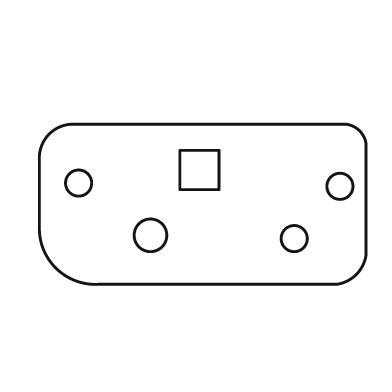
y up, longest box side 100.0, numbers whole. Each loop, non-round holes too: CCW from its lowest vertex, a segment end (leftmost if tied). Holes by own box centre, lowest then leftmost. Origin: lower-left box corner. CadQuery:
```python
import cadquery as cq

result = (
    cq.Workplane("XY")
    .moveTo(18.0, 0.0)
    .lineTo(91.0, 0.0)
    .threePointArc((97.0, 3.0), (100.0, 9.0))
    .lineTo(100.0, 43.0)
    .threePointArc((98.0, 47.0), (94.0, 49.0))
    .lineTo(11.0, 49.0)
    .threePointArc((3.0, 46.0), (0.0, 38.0))
    .lineTo(0.0, 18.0)
    .threePointArc((5.0, 5.0), (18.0, 0.0))
    .close()
    .moveTo(78.0, 14.0)
    .circle(4.0)
    .moveTo(34.0, 15.0)
    .circle(5.0)
    .moveTo(92.0, 30.0)
    .circle(4.0)
    .moveTo(12.0, 31.0)
    .circle(4.0)
    .moveTo(43.0, 29.0)
    .lineTo(55.0, 29.0)
    .lineTo(55.0, 41.0)
    .lineTo(43.0, 41.0)
    .close()
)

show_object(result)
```